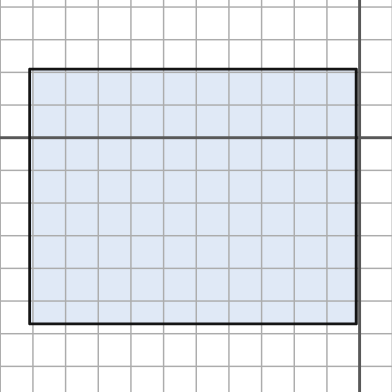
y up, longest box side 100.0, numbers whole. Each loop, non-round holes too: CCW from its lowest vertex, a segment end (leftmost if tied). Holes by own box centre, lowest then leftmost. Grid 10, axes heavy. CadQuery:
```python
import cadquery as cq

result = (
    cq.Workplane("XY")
    .moveTo(-101.0, -57.0)
    .lineTo(-1.0, -57.0)
    .lineTo(-1.0, 21.0)
    .lineTo(-101.0, 21.0)
    .close()
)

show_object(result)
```